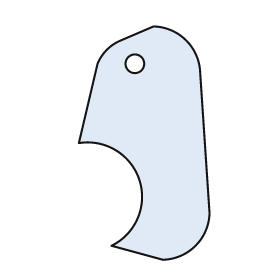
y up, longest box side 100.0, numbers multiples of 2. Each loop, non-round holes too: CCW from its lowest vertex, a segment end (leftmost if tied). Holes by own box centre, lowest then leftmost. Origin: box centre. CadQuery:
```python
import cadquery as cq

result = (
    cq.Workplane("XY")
    .moveTo(8.0, -50.0)
    .threePointArc((22.0, -44.0), (28.0, -30.0))
    .lineTo(24.0, 30.0)
    .threePointArc((18.0, 44.0), (4.0, 50.0))
    .lineTo(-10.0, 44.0)
    .threePointArc((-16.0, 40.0), (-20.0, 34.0))
    .lineTo(-28.0, 0.0)
    .threePointArc((-2.0, -16.0), (-14.0, -44.0))
    .close()
    .moveTo(-4.0, 34.0)
    .circle(4.0)
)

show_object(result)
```